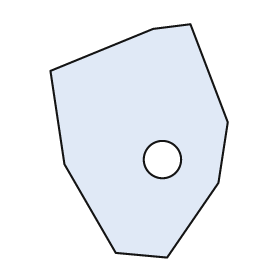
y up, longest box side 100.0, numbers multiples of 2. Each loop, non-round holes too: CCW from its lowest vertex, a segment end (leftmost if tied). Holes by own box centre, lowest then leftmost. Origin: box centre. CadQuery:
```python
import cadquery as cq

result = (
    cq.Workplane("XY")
    .moveTo(12.0, -50.0)
    .lineTo(34.0, -18.0)
    .lineTo(38.0, 8.0)
    .lineTo(22.0, 50.0)
    .lineTo(6.0, 48.0)
    .lineTo(-38.0, 30.0)
    .lineTo(-32.0, -10.0)
    .lineTo(-10.0, -48.0)
    .close()
    .moveTo(10.0, -8.0)
    .circle(8.0)
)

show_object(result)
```